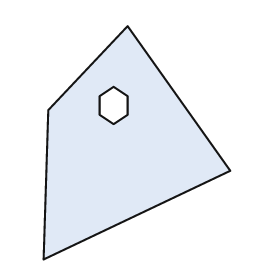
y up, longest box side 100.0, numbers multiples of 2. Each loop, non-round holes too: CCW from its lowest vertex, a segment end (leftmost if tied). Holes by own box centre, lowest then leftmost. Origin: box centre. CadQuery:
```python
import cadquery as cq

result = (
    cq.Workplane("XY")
    .moveTo(-40.0, -50.0)
    .lineTo(40.0, -12.0)
    .lineTo(-4.0, 50.0)
    .lineTo(-38.0, 14.0)
    .close()
    .moveTo(-10.0, 8.0)
    .lineTo(-4.0, 12.0)
    .lineTo(-4.0, 20.0)
    .lineTo(-10.0, 24.0)
    .lineTo(-16.0, 20.0)
    .lineTo(-16.0, 12.0)
    .close()
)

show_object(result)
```